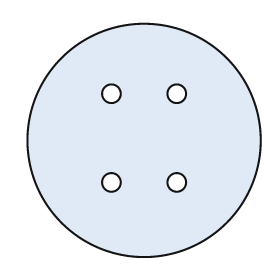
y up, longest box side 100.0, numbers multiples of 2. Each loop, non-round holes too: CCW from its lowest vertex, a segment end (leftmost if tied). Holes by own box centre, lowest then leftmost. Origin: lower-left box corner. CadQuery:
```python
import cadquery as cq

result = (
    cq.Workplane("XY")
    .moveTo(50.0, 50.0)
    .circle(50.0)
    .moveTo(36.0, 32.0)
    .circle(4.0)
    .moveTo(64.0, 32.0)
    .circle(4.0)
    .moveTo(36.0, 70.0)
    .circle(4.0)
    .moveTo(64.0, 70.0)
    .circle(4.0)
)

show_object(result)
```